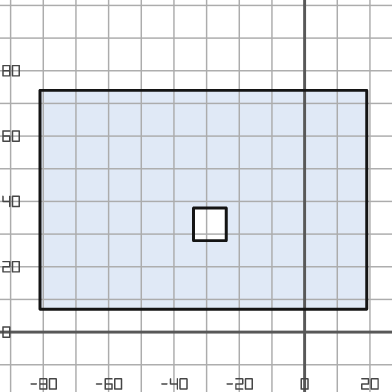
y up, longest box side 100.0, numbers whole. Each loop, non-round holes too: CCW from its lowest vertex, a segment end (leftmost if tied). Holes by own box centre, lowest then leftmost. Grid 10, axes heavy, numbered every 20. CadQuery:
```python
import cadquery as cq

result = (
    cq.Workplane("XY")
    .moveTo(-81.0, 7.0)
    .lineTo(19.0, 7.0)
    .lineTo(19.0, 74.0)
    .lineTo(-81.0, 74.0)
    .close()
    .moveTo(-34.0, 28.0)
    .lineTo(-24.0, 28.0)
    .lineTo(-24.0, 38.0)
    .lineTo(-34.0, 38.0)
    .close()
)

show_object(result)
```